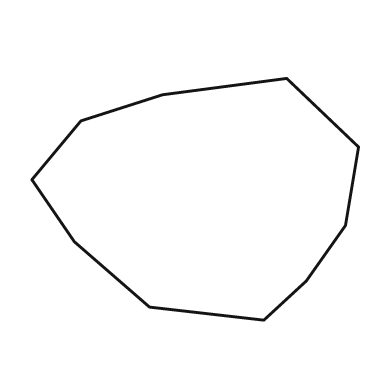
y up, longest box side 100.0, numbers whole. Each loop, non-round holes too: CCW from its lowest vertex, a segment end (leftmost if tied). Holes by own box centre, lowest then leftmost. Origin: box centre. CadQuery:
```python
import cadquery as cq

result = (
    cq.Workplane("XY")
    .moveTo(21.0, -37.0)
    .lineTo(34.0, -25.0)
    .lineTo(46.0, -8.0)
    .lineTo(50.0, 16.0)
    .lineTo(28.0, 37.0)
    .lineTo(-10.0, 32.0)
    .lineTo(-35.0, 24.0)
    .lineTo(-50.0, 6.0)
    .lineTo(-37.0, -13.0)
    .lineTo(-14.0, -33.0)
    .close()
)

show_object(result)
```